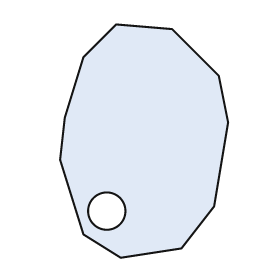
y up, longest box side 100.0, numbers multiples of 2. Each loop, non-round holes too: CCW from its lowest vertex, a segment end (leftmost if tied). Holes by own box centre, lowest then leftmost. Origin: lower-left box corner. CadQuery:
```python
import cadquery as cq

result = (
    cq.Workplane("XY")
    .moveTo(26.0, 0.0)
    .lineTo(52.0, 4.0)
    .lineTo(66.0, 22.0)
    .lineTo(72.0, 58.0)
    .lineTo(68.0, 78.0)
    .lineTo(48.0, 98.0)
    .lineTo(24.0, 100.0)
    .lineTo(10.0, 86.0)
    .lineTo(2.0, 60.0)
    .lineTo(0.0, 42.0)
    .lineTo(10.0, 10.0)
    .close()
    .moveTo(20.0, 20.0)
    .circle(8.0)
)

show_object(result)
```